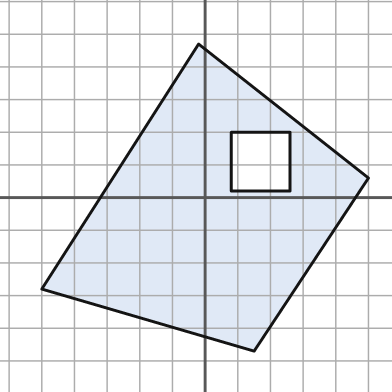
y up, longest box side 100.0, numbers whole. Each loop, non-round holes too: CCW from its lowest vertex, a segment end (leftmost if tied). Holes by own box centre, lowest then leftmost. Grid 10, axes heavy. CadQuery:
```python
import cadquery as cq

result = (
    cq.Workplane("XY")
    .moveTo(15.0, -47.0)
    .lineTo(50.0, 6.0)
    .lineTo(-2.0, 47.0)
    .lineTo(-50.0, -28.0)
    .close()
    .moveTo(8.0, 2.0)
    .lineTo(26.0, 2.0)
    .lineTo(26.0, 20.0)
    .lineTo(8.0, 20.0)
    .close()
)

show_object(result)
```